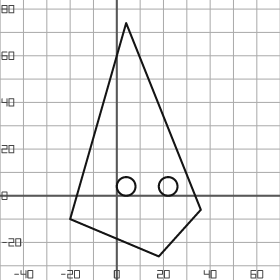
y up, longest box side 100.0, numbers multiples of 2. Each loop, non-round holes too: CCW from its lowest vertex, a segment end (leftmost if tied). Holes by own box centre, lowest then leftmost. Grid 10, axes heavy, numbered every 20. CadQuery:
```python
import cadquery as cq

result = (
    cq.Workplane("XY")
    .moveTo(18.0, -26.0)
    .lineTo(36.0, -6.0)
    .lineTo(4.0, 74.0)
    .lineTo(-20.0, -10.0)
    .close()
    .moveTo(4.0, 4.0)
    .circle(4.0)
    .moveTo(22.0, 4.0)
    .circle(4.0)
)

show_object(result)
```